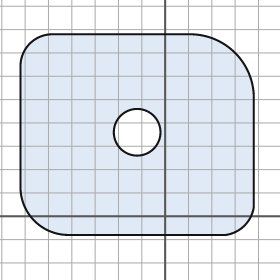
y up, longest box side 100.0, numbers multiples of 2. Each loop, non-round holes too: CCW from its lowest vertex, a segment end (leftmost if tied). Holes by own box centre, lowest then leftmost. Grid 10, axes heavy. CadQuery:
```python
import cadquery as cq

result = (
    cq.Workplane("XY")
    .moveTo(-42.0, -8.0)
    .lineTo(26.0, -8.0)
    .threePointArc((34.0, -4.0), (38.0, 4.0))
    .lineTo(38.0, 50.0)
    .threePointArc((30.0, 70.0), (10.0, 78.0))
    .lineTo(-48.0, 78.0)
    .threePointArc((-58.0, 74.0), (-62.0, 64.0))
    .lineTo(-62.0, 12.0)
    .threePointArc((-56.0, -2.0), (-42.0, -8.0))
    .close()
    .moveTo(-12.0, 36.0)
    .circle(10.0)
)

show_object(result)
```